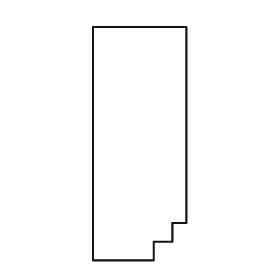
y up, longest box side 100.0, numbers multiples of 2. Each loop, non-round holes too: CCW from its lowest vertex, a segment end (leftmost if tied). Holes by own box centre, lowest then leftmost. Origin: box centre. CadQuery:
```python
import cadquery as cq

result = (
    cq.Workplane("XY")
    .moveTo(-20.0, -50.0)
    .lineTo(6.0, -50.0)
    .lineTo(6.0, -42.0)
    .lineTo(14.0, -42.0)
    .lineTo(14.0, -34.0)
    .lineTo(20.0, -34.0)
    .lineTo(20.0, 50.0)
    .lineTo(-20.0, 50.0)
    .close()
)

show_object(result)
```